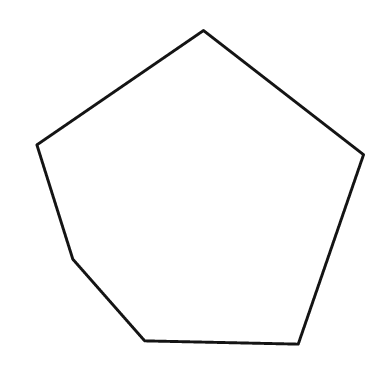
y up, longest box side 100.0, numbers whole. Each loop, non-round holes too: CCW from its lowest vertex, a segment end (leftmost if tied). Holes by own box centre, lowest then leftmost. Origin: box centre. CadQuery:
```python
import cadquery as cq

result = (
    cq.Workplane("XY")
    .moveTo(30.0, -48.0)
    .lineTo(50.0, 10.0)
    .lineTo(1.0, 48.0)
    .lineTo(-50.0, 13.0)
    .lineTo(-39.0, -22.0)
    .lineTo(-17.0, -47.0)
    .close()
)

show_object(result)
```